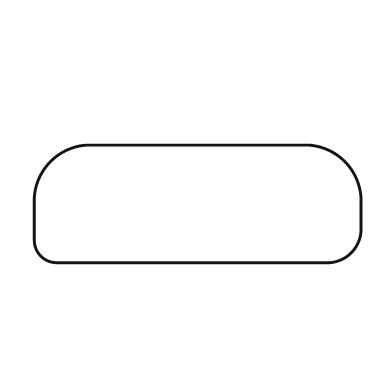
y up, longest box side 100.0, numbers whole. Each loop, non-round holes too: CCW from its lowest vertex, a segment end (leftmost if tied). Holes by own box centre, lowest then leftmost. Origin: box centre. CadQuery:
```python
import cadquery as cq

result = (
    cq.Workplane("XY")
    .moveTo(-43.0, -18.0)
    .lineTo(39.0, -18.0)
    .threePointArc((47.0, -15.0), (50.0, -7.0))
    .lineTo(50.0, 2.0)
    .threePointArc((45.0, 13.0), (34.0, 18.0))
    .lineTo(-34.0, 18.0)
    .threePointArc((-45.0, 13.0), (-50.0, 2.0))
    .lineTo(-50.0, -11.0)
    .threePointArc((-48.0, -16.0), (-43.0, -18.0))
    .close()
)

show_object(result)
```